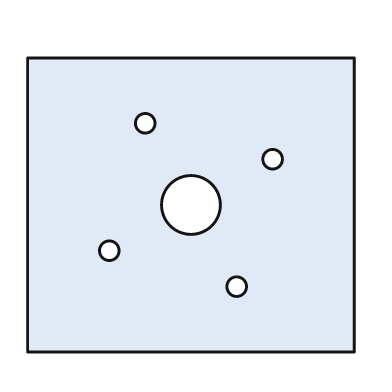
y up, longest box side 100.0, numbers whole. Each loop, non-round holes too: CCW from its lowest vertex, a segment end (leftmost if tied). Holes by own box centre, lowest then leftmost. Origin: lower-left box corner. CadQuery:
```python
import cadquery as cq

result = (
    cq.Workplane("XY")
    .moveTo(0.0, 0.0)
    .lineTo(100.0, 0.0)
    .lineTo(100.0, 90.0)
    .lineTo(0.0, 90.0)
    .close()
    .moveTo(64.0, 20.0)
    .circle(3.0)
    .moveTo(25.0, 31.0)
    .circle(3.0)
    .moveTo(50.0, 45.0)
    .circle(9.0)
    .moveTo(75.0, 59.0)
    .circle(3.0)
    .moveTo(36.0, 70.0)
    .circle(3.0)
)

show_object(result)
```